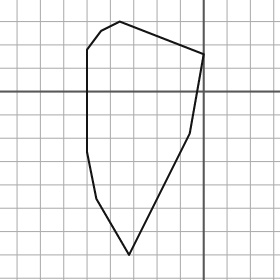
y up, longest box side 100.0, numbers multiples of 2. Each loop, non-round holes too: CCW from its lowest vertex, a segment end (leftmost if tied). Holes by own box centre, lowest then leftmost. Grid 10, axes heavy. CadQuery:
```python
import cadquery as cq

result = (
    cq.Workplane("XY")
    .moveTo(-32.0, -70.0)
    .lineTo(-6.0, -18.0)
    .lineTo(0.0, 16.0)
    .lineTo(-36.0, 30.0)
    .lineTo(-44.0, 26.0)
    .lineTo(-50.0, 18.0)
    .lineTo(-50.0, -26.0)
    .lineTo(-46.0, -46.0)
    .close()
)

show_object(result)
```